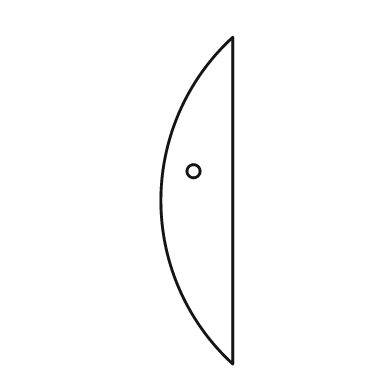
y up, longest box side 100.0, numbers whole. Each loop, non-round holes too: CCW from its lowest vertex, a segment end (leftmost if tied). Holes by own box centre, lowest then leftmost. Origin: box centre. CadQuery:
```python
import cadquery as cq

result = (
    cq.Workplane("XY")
    .moveTo(11.0, -50.0)
    .lineTo(11.0, 50.0)
    .threePointArc((-11.0, 0.0), (11.0, -50.0))
    .close()
    .moveTo(-1.0, 9.0)
    .circle(2.0)
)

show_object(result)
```